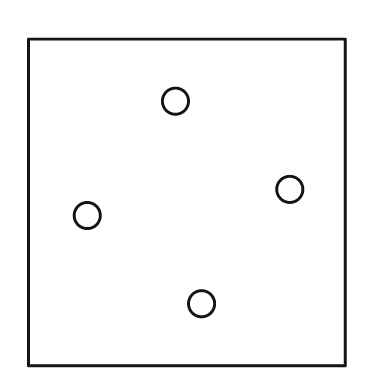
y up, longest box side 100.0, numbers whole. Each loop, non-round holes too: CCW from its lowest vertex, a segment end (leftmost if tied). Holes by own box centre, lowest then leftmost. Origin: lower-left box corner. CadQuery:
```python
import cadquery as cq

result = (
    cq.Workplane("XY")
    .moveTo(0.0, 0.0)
    .lineTo(97.0, 0.0)
    .lineTo(97.0, 100.0)
    .lineTo(0.0, 100.0)
    .close()
    .moveTo(53.0, 19.0)
    .circle(4.0)
    .moveTo(18.0, 46.0)
    .circle(4.0)
    .moveTo(80.0, 54.0)
    .circle(4.0)
    .moveTo(45.0, 81.0)
    .circle(4.0)
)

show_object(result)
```